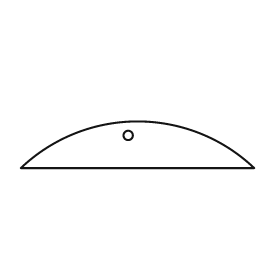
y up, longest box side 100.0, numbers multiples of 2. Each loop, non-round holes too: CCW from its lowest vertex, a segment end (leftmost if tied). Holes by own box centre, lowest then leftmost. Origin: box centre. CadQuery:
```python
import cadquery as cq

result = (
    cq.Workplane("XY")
    .moveTo(-50.0, -10.0)
    .lineTo(50.0, -10.0)
    .threePointArc((0.0, 10.0), (-50.0, -10.0))
    .close()
    .moveTo(-4.0, 4.0)
    .circle(2.0)
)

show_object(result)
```